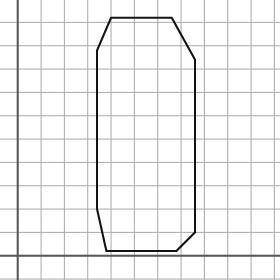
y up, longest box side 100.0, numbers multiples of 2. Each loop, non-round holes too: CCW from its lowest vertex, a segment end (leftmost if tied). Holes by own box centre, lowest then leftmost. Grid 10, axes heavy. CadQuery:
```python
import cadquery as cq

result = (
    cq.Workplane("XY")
    .moveTo(38.0, 2.0)
    .lineTo(68.0, 2.0)
    .lineTo(76.0, 10.0)
    .lineTo(76.0, 84.0)
    .lineTo(66.0, 102.0)
    .lineTo(40.0, 102.0)
    .lineTo(34.0, 88.0)
    .lineTo(34.0, 20.0)
    .close()
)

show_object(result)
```